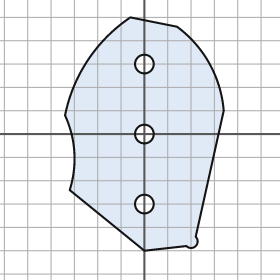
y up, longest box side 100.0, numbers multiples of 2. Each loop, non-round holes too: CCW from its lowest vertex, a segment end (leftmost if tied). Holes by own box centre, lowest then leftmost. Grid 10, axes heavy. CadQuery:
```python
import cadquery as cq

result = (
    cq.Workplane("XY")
    .moveTo(0.0, -50.0)
    .lineTo(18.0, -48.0)
    .threePointArc((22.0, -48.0), (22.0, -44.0))
    .lineTo(34.0, 10.0)
    .threePointArc((28.0, 30.0), (14.0, 46.0))
    .lineTo(-6.0, 50.0)
    .threePointArc((-24.0, 32.0), (-34.0, 8.0))
    .threePointArc((-30.0, -8.0), (-32.0, -24.0))
    .close()
    .moveTo(0.0, -30.0)
    .circle(4.0)
    .moveTo(0.0, 0.0)
    .circle(4.0)
    .moveTo(0.0, 30.0)
    .circle(4.0)
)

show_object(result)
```